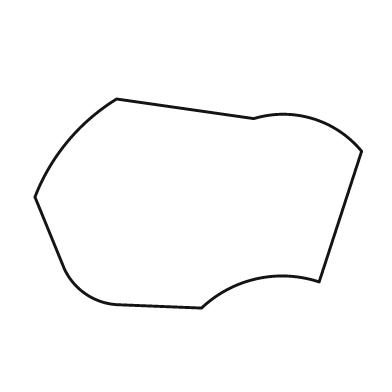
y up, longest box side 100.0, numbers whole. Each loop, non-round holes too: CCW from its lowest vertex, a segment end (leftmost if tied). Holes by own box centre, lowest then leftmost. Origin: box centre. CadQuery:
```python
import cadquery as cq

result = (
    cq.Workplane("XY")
    .moveTo(1.0, -32.0)
    .threePointArc((18.0, -23.0), (37.0, -24.0))
    .lineTo(50.0, 16.0)
    .threePointArc((35.0, 26.0), (17.0, 26.0))
    .lineTo(-25.0, 32.0)
    .threePointArc((-40.0, 19.0), (-50.0, 2.0))
    .lineTo(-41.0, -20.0)
    .threePointArc((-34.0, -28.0), (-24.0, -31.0))
    .close()
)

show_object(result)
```